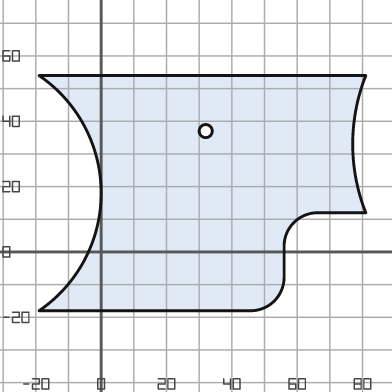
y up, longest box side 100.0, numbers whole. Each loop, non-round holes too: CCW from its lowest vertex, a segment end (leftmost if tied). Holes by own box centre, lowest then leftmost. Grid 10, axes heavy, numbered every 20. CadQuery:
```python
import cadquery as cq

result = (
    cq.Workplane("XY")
    .moveTo(-19.0, -18.0)
    .lineTo(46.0, -18.0)
    .threePointArc((53.0, -15.0), (56.0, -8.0))
    .lineTo(56.0, 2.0)
    .threePointArc((59.0, 9.0), (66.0, 12.0))
    .lineTo(81.0, 12.0)
    .threePointArc((77.0, 33.0), (81.0, 54.0))
    .lineTo(-19.0, 54.0)
    .threePointArc((0.0, 18.0), (-19.0, -18.0))
    .close()
    .moveTo(32.0, 37.0)
    .circle(2.0)
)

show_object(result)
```